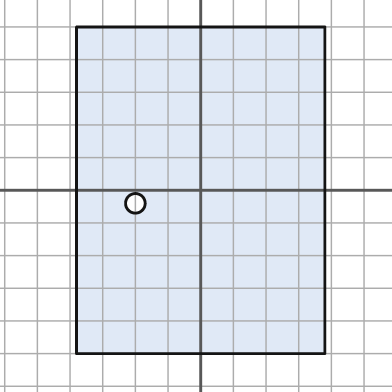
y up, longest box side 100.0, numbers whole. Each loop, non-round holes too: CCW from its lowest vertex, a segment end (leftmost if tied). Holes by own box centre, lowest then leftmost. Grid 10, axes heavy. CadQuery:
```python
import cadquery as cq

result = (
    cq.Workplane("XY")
    .moveTo(-38.0, -50.0)
    .lineTo(38.0, -50.0)
    .lineTo(38.0, 50.0)
    .lineTo(-38.0, 50.0)
    .close()
    .moveTo(-20.0, -4.0)
    .circle(3.0)
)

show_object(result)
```